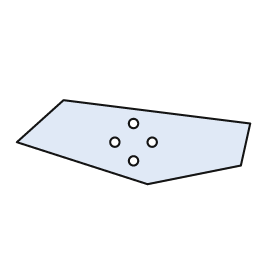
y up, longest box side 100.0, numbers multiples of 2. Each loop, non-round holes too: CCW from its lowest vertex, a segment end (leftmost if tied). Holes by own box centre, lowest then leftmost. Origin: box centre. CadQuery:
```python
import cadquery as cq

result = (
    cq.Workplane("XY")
    .moveTo(6.0, -18.0)
    .lineTo(46.0, -10.0)
    .lineTo(50.0, 8.0)
    .lineTo(-30.0, 18.0)
    .lineTo(-50.0, 0.0)
    .close()
    .moveTo(0.0, -8.0)
    .circle(2.0)
    .moveTo(-8.0, 0.0)
    .circle(2.0)
    .moveTo(8.0, 0.0)
    .circle(2.0)
    .moveTo(0.0, 8.0)
    .circle(2.0)
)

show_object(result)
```